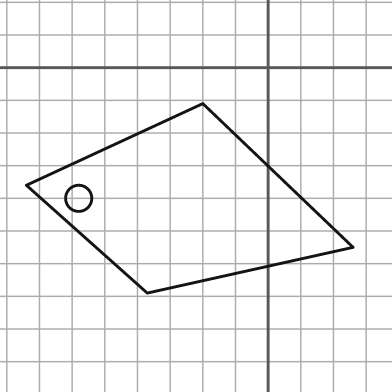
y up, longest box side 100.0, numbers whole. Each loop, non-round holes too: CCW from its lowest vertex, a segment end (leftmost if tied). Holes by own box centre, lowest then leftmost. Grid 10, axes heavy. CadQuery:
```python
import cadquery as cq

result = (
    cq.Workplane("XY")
    .moveTo(-37.0, -69.0)
    .lineTo(26.0, -55.0)
    .lineTo(-20.0, -11.0)
    .lineTo(-74.0, -36.0)
    .close()
    .moveTo(-58.0, -40.0)
    .circle(4.0)
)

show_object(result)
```